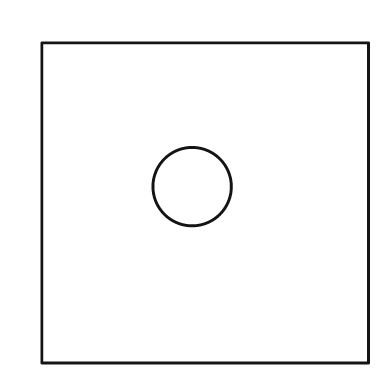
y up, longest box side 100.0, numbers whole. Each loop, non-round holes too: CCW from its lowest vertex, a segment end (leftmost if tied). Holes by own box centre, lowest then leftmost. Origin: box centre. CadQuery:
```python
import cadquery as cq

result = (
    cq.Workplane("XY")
    .moveTo(-50.0, -49.0)
    .lineTo(50.0, -49.0)
    .lineTo(50.0, 49.0)
    .lineTo(-50.0, 49.0)
    .close()
    .moveTo(-4.0, 5.0)
    .circle(12.0)
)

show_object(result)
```